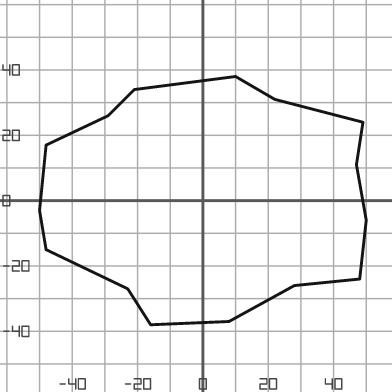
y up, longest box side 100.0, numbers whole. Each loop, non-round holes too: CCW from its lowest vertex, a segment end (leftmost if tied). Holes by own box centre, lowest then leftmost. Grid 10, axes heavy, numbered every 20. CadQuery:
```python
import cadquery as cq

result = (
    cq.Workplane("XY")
    .moveTo(-16.0, -38.0)
    .lineTo(8.0, -37.0)
    .lineTo(28.0, -26.0)
    .lineTo(48.0, -24.0)
    .lineTo(50.0, -6.0)
    .lineTo(47.0, 11.0)
    .lineTo(49.0, 24.0)
    .lineTo(22.0, 31.0)
    .lineTo(10.0, 38.0)
    .lineTo(-21.0, 34.0)
    .lineTo(-29.0, 26.0)
    .lineTo(-48.0, 17.0)
    .lineTo(-50.0, -3.0)
    .lineTo(-48.0, -15.0)
    .lineTo(-23.0, -27.0)
    .close()
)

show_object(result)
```